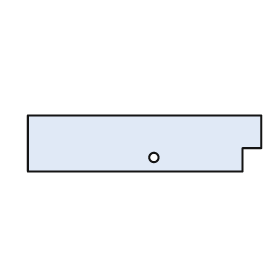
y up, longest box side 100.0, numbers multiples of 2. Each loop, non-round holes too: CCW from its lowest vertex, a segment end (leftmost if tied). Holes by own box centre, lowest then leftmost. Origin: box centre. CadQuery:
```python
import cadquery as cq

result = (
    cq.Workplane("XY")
    .moveTo(-50.0, -12.0)
    .lineTo(42.0, -12.0)
    .lineTo(42.0, -2.0)
    .lineTo(50.0, -2.0)
    .lineTo(50.0, 12.0)
    .lineTo(-50.0, 12.0)
    .close()
    .moveTo(4.0, -6.0)
    .circle(2.0)
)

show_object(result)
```